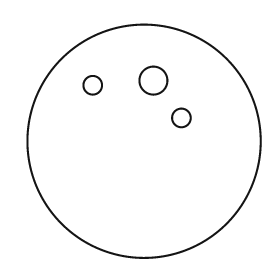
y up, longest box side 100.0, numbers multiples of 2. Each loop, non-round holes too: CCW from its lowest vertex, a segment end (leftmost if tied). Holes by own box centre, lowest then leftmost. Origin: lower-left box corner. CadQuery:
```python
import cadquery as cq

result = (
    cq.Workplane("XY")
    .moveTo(50.0, 50.0)
    .circle(50.0)
    .moveTo(66.0, 60.0)
    .circle(4.0)
    .moveTo(28.0, 74.0)
    .circle(4.0)
    .moveTo(54.0, 76.0)
    .circle(6.0)
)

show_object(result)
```